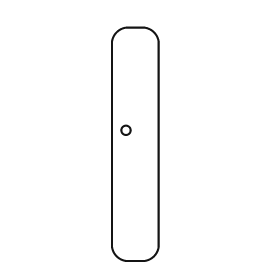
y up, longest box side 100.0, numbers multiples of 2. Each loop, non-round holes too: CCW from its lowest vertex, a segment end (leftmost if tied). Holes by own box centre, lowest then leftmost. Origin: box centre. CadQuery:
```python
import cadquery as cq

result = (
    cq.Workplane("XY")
    .moveTo(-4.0, -50.0)
    .lineTo(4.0, -50.0)
    .threePointArc((8.0, -48.0), (10.0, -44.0))
    .lineTo(10.0, 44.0)
    .threePointArc((8.0, 48.0), (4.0, 50.0))
    .lineTo(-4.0, 50.0)
    .threePointArc((-8.0, 48.0), (-10.0, 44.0))
    .lineTo(-10.0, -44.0)
    .threePointArc((-8.0, -48.0), (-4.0, -50.0))
    .close()
    .moveTo(-4.0, 6.0)
    .circle(2.0)
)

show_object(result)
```